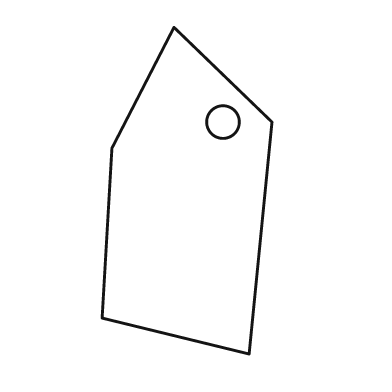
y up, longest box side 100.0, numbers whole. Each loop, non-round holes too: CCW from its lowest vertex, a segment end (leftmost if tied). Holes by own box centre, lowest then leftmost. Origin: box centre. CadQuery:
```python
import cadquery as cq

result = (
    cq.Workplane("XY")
    .moveTo(19.0, -50.0)
    .lineTo(26.0, 21.0)
    .lineTo(-4.0, 50.0)
    .lineTo(-23.0, 13.0)
    .lineTo(-26.0, -39.0)
    .close()
    .moveTo(11.0, 21.0)
    .circle(5.0)
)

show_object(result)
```